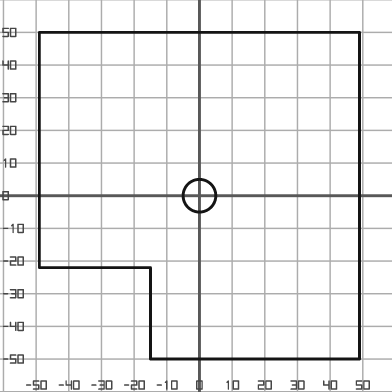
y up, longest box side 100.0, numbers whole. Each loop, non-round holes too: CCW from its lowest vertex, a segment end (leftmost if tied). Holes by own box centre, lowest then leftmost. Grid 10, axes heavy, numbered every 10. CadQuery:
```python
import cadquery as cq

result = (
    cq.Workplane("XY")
    .moveTo(-15.0, -50.0)
    .lineTo(49.0, -50.0)
    .lineTo(49.0, 50.0)
    .lineTo(-49.0, 50.0)
    .lineTo(-49.0, -22.0)
    .lineTo(-15.0, -22.0)
    .close()
    .moveTo(0.0, 0.0)
    .circle(5.0)
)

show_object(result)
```